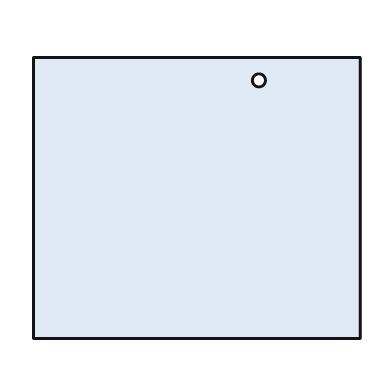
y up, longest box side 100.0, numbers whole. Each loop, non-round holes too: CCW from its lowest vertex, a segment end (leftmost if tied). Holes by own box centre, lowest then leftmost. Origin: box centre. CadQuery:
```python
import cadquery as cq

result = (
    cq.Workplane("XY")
    .moveTo(-50.0, -43.0)
    .lineTo(50.0, -43.0)
    .lineTo(50.0, 43.0)
    .lineTo(-50.0, 43.0)
    .close()
    .moveTo(19.0, 36.0)
    .circle(2.0)
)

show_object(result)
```